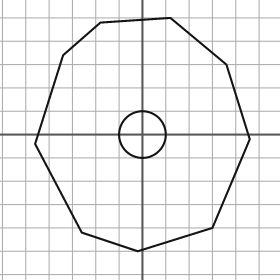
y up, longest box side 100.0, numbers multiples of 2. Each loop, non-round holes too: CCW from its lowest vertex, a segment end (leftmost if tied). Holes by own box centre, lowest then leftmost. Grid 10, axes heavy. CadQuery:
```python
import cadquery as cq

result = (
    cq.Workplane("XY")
    .moveTo(-2.0, -50.0)
    .lineTo(30.0, -40.0)
    .lineTo(46.0, -2.0)
    .lineTo(36.0, 30.0)
    .lineTo(12.0, 50.0)
    .lineTo(-18.0, 48.0)
    .lineTo(-34.0, 34.0)
    .lineTo(-46.0, -4.0)
    .lineTo(-26.0, -42.0)
    .close()
    .moveTo(0.0, 0.0)
    .circle(10.0)
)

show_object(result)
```